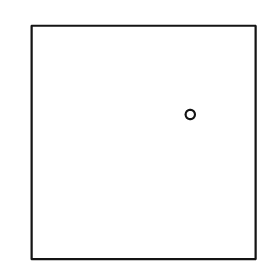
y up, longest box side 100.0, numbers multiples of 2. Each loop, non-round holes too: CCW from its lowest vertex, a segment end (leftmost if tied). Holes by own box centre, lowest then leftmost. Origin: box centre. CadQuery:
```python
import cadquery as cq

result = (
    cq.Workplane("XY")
    .moveTo(-48.0, -50.0)
    .lineTo(48.0, -50.0)
    .lineTo(48.0, 50.0)
    .lineTo(-48.0, 50.0)
    .close()
    .moveTo(20.0, 12.0)
    .circle(2.0)
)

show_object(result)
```